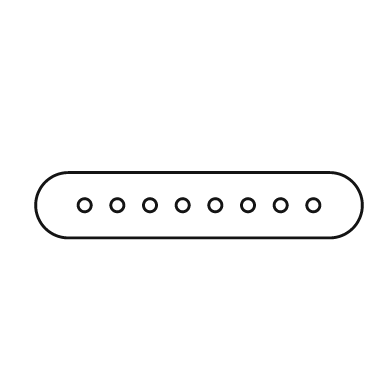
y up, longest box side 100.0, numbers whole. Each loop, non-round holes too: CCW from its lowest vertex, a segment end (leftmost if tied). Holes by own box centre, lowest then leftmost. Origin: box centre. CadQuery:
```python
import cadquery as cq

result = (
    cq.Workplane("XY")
    .moveTo(-40.0, -10.0)
    .lineTo(40.0, -10.0)
    .threePointArc((50.0, 0.0), (40.0, 10.0))
    .lineTo(-40.0, 10.0)
    .threePointArc((-50.0, 0.0), (-40.0, -10.0))
    .close()
    .moveTo(-35.0, 0.0)
    .circle(2.0)
    .moveTo(-25.0, 0.0)
    .circle(2.0)
    .moveTo(-15.0, 0.0)
    .circle(2.0)
    .moveTo(-5.0, 0.0)
    .circle(2.0)
    .moveTo(5.0, 0.0)
    .circle(2.0)
    .moveTo(15.0, 0.0)
    .circle(2.0)
    .moveTo(25.0, 0.0)
    .circle(2.0)
    .moveTo(35.0, 0.0)
    .circle(2.0)
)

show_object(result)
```